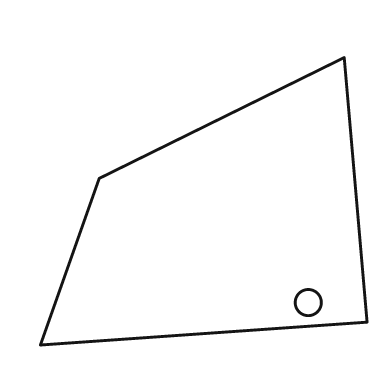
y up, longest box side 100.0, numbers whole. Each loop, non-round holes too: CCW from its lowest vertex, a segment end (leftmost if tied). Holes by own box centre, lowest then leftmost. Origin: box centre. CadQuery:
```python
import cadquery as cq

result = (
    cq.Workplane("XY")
    .moveTo(-50.0, -44.0)
    .lineTo(50.0, -37.0)
    .lineTo(43.0, 44.0)
    .lineTo(-32.0, 7.0)
    .close()
    .moveTo(32.0, -31.0)
    .circle(4.0)
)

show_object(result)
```